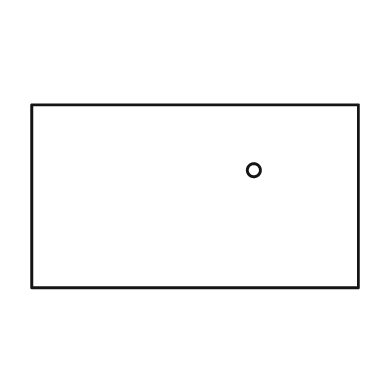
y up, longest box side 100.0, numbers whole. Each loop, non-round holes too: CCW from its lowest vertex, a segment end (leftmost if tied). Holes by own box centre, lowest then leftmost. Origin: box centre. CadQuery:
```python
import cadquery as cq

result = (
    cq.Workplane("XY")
    .moveTo(-50.0, -28.0)
    .lineTo(50.0, -28.0)
    .lineTo(50.0, 28.0)
    .lineTo(-50.0, 28.0)
    .close()
    .moveTo(18.0, 8.0)
    .circle(2.0)
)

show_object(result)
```